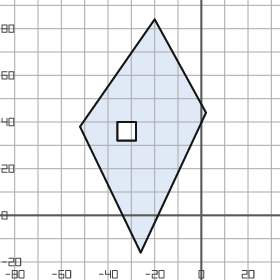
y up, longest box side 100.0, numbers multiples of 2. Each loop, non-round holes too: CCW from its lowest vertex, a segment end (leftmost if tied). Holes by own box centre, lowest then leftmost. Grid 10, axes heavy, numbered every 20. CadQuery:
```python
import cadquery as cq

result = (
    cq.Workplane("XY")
    .moveTo(-26.0, -16.0)
    .lineTo(2.0, 44.0)
    .lineTo(-20.0, 84.0)
    .lineTo(-52.0, 38.0)
    .close()
    .moveTo(-36.0, 32.0)
    .lineTo(-28.0, 32.0)
    .lineTo(-28.0, 40.0)
    .lineTo(-36.0, 40.0)
    .close()
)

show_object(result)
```